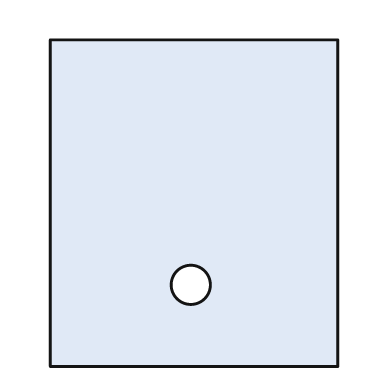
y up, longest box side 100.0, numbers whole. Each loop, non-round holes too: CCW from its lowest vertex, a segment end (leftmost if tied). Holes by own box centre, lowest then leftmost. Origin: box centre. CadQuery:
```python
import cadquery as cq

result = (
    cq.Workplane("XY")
    .moveTo(-44.0, -50.0)
    .lineTo(44.0, -50.0)
    .lineTo(44.0, 50.0)
    .lineTo(-44.0, 50.0)
    .close()
    .moveTo(-1.0, -25.0)
    .circle(6.0)
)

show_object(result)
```